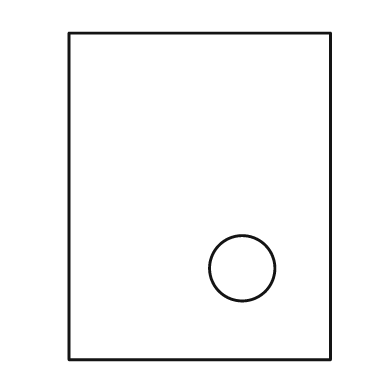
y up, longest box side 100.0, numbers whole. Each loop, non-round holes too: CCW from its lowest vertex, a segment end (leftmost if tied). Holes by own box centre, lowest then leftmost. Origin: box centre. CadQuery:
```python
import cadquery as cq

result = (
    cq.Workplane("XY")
    .moveTo(-40.0, -50.0)
    .lineTo(40.0, -50.0)
    .lineTo(40.0, 50.0)
    .lineTo(-40.0, 50.0)
    .close()
    .moveTo(13.0, -22.0)
    .circle(10.0)
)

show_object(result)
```